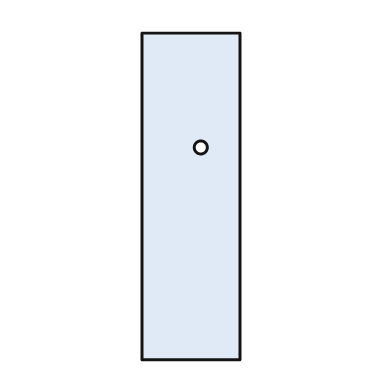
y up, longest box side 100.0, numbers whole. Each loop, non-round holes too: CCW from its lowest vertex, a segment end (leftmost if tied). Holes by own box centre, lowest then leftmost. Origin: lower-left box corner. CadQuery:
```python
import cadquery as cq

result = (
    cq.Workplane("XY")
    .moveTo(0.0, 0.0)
    .lineTo(30.0, 0.0)
    .lineTo(30.0, 100.0)
    .lineTo(0.0, 100.0)
    .close()
    .moveTo(18.0, 65.0)
    .circle(2.0)
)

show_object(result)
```